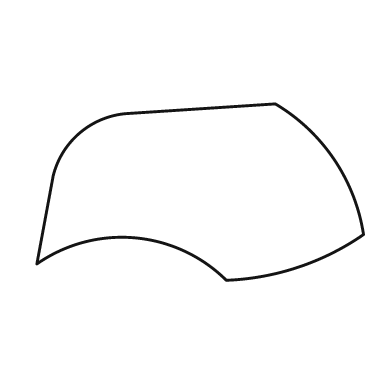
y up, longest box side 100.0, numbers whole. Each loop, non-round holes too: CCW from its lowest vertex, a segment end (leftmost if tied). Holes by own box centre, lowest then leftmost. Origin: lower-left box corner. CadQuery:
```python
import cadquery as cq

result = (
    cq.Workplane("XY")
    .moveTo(58.0, 0.0)
    .threePointArc((80.0, 4.0), (100.0, 14.0))
    .threePointArc((91.0, 37.0), (73.0, 54.0))
    .lineTo(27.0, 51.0)
    .threePointArc((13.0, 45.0), (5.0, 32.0))
    .lineTo(0.0, 5.0)
    .threePointArc((30.0, 13.0), (58.0, 0.0))
    .close()
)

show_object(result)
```